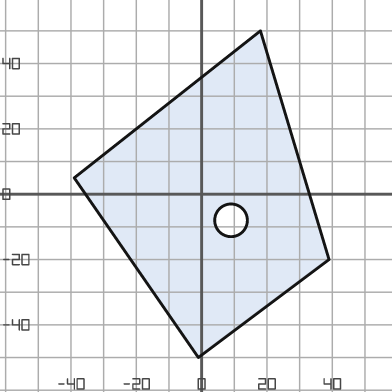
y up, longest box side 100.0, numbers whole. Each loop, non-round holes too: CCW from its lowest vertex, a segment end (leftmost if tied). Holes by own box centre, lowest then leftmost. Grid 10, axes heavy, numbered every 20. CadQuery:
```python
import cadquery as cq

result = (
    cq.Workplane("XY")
    .moveTo(-1.0, -50.0)
    .lineTo(39.0, -20.0)
    .lineTo(18.0, 50.0)
    .lineTo(-39.0, 5.0)
    .close()
    .moveTo(9.0, -8.0)
    .circle(5.0)
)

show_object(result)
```